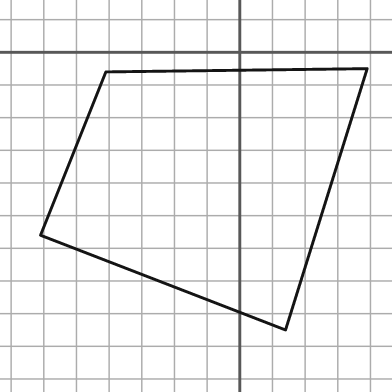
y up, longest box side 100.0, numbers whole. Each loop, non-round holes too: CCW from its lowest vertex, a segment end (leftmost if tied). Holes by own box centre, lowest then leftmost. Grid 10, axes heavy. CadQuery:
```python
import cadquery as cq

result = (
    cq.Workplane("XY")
    .moveTo(14.0, -85.0)
    .lineTo(39.0, -5.0)
    .lineTo(-41.0, -6.0)
    .lineTo(-61.0, -56.0)
    .close()
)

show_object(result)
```